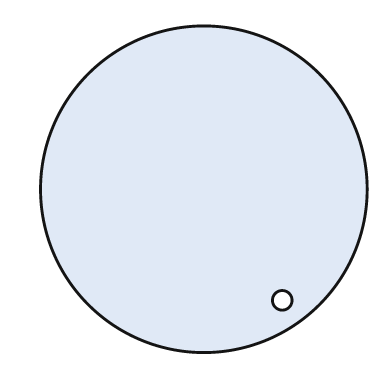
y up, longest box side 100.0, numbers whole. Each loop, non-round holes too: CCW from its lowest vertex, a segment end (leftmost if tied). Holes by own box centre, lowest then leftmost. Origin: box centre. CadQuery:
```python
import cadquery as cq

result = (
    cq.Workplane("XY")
    .moveTo(0.0, 0.0)
    .circle(50.0)
    .moveTo(24.0, -34.0)
    .circle(3.0)
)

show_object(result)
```